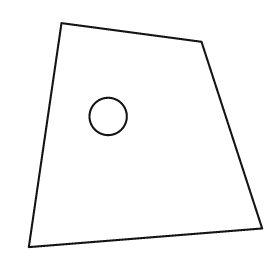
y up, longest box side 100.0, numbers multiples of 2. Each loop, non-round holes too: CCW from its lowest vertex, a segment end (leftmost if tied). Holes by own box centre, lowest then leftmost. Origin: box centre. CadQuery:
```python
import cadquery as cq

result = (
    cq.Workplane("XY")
    .moveTo(-50.0, -48.0)
    .lineTo(50.0, -40.0)
    .lineTo(24.0, 40.0)
    .lineTo(-36.0, 48.0)
    .close()
    .moveTo(-16.0, 8.0)
    .circle(8.0)
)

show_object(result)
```